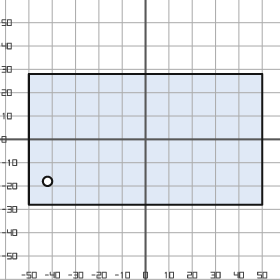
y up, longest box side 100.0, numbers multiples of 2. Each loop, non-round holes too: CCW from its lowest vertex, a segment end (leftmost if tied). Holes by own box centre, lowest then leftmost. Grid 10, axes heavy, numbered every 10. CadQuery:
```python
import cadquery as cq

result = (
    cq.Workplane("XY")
    .moveTo(-50.0, -28.0)
    .lineTo(50.0, -28.0)
    .lineTo(50.0, 28.0)
    .lineTo(-50.0, 28.0)
    .close()
    .moveTo(-42.0, -18.0)
    .circle(2.0)
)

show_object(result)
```